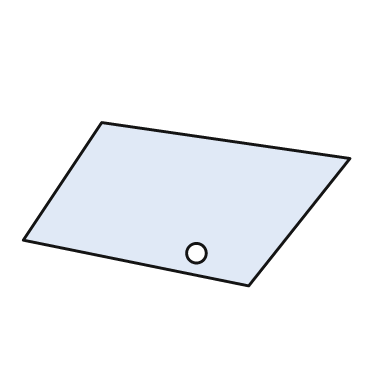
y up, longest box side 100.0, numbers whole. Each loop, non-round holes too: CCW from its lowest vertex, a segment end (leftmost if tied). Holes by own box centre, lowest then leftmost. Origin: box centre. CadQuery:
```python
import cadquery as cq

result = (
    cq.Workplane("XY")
    .moveTo(19.0, -25.0)
    .lineTo(50.0, 14.0)
    .lineTo(-26.0, 25.0)
    .lineTo(-50.0, -11.0)
    .close()
    .moveTo(3.0, -15.0)
    .circle(3.0)
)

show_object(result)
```